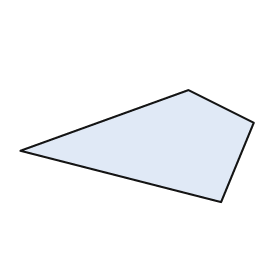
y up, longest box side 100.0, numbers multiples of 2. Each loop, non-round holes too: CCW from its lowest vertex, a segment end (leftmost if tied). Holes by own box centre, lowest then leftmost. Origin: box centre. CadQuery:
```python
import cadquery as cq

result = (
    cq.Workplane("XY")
    .moveTo(36.0, -24.0)
    .lineTo(50.0, 10.0)
    .lineTo(22.0, 24.0)
    .lineTo(-50.0, -2.0)
    .close()
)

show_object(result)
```